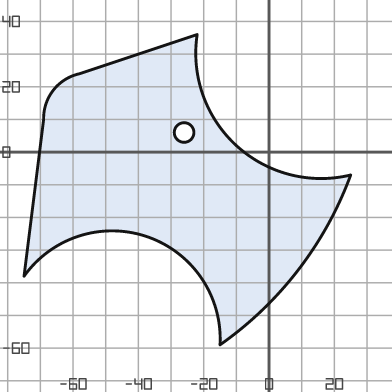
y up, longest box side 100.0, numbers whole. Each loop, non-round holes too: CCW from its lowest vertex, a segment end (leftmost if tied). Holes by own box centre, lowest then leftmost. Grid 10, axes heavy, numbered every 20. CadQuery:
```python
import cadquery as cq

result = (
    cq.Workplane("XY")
    .moveTo(-15.0, -59.0)
    .threePointArc((9.0, -36.0), (25.0, -7.0))
    .threePointArc((-10.0, 2.0), (-22.0, 36.0))
    .lineTo(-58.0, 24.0)
    .threePointArc((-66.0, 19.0), (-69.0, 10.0))
    .lineTo(-75.0, -38.0)
    .threePointArc((-37.0, -26.0), (-15.0, -59.0))
    .close()
    .moveTo(-26.0, 6.0)
    .circle(3.0)
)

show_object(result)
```